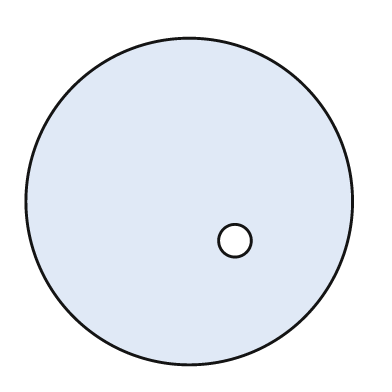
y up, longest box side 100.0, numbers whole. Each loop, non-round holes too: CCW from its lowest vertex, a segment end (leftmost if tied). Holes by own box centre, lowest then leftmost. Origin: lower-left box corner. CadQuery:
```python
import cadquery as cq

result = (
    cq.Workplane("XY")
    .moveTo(50.0, 50.0)
    .circle(50.0)
    .moveTo(64.0, 38.0)
    .circle(5.0)
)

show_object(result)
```